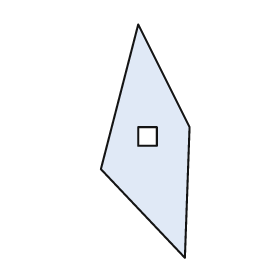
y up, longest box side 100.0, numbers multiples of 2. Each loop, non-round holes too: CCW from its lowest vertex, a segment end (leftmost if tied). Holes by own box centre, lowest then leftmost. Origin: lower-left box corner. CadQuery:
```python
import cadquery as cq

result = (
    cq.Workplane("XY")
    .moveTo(36.0, 0.0)
    .lineTo(38.0, 56.0)
    .lineTo(16.0, 100.0)
    .lineTo(0.0, 38.0)
    .close()
    .moveTo(16.0, 48.0)
    .lineTo(24.0, 48.0)
    .lineTo(24.0, 56.0)
    .lineTo(16.0, 56.0)
    .close()
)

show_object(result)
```